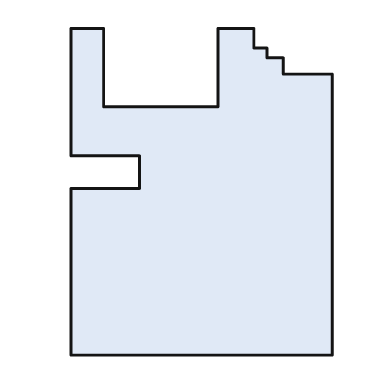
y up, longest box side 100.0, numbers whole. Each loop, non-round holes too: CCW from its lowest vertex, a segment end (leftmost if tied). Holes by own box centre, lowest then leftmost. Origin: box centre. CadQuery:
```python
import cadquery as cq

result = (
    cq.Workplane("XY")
    .moveTo(-40.0, -50.0)
    .lineTo(40.0, -50.0)
    .lineTo(40.0, 36.0)
    .lineTo(25.0, 36.0)
    .lineTo(25.0, 41.0)
    .lineTo(20.0, 41.0)
    .lineTo(20.0, 44.0)
    .lineTo(16.0, 44.0)
    .lineTo(16.0, 50.0)
    .lineTo(5.0, 50.0)
    .lineTo(5.0, 26.0)
    .lineTo(-30.0, 26.0)
    .lineTo(-30.0, 50.0)
    .lineTo(-40.0, 50.0)
    .lineTo(-40.0, 11.0)
    .lineTo(-19.0, 11.0)
    .lineTo(-19.0, 1.0)
    .lineTo(-40.0, 1.0)
    .close()
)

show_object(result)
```